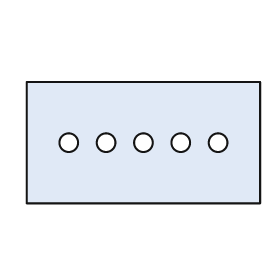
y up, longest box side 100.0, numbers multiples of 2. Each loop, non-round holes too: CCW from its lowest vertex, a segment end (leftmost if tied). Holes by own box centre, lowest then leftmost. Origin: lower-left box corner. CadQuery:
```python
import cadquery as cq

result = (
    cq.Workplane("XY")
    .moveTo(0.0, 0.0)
    .lineTo(100.0, 0.0)
    .lineTo(100.0, 52.0)
    .lineTo(0.0, 52.0)
    .close()
    .moveTo(18.0, 26.0)
    .circle(4.0)
    .moveTo(34.0, 26.0)
    .circle(4.0)
    .moveTo(50.0, 26.0)
    .circle(4.0)
    .moveTo(66.0, 26.0)
    .circle(4.0)
    .moveTo(82.0, 26.0)
    .circle(4.0)
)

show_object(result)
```